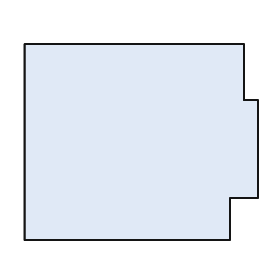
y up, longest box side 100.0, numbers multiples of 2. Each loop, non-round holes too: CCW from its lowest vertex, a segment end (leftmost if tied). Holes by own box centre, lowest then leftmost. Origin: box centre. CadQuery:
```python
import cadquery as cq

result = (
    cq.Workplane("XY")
    .moveTo(-50.0, -42.0)
    .lineTo(38.0, -42.0)
    .lineTo(38.0, -24.0)
    .lineTo(50.0, -24.0)
    .lineTo(50.0, 18.0)
    .lineTo(44.0, 18.0)
    .lineTo(44.0, 42.0)
    .lineTo(-50.0, 42.0)
    .close()
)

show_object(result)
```